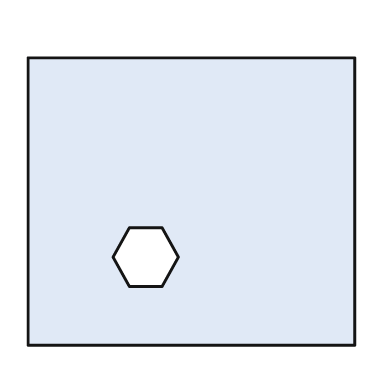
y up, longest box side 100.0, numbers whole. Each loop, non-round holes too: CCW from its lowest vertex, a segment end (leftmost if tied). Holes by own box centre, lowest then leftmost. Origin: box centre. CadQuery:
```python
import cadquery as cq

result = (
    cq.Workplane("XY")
    .moveTo(-50.0, -44.0)
    .lineTo(50.0, -44.0)
    .lineTo(50.0, 44.0)
    .lineTo(-50.0, 44.0)
    .close()
    .moveTo(-19.0, -26.0)
    .lineTo(-9.0, -26.0)
    .lineTo(-4.0, -17.0)
    .lineTo(-9.0, -8.0)
    .lineTo(-19.0, -8.0)
    .lineTo(-24.0, -17.0)
    .close()
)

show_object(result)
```